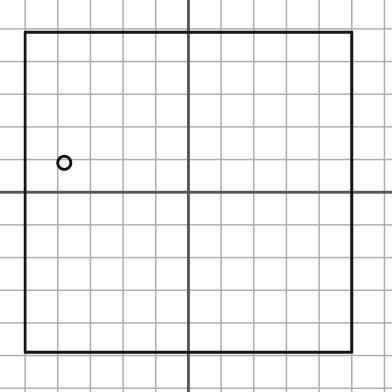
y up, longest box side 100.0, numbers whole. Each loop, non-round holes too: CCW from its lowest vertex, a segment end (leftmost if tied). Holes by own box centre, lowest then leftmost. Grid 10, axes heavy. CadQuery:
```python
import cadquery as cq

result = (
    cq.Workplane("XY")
    .moveTo(-50.0, -49.0)
    .lineTo(50.0, -49.0)
    .lineTo(50.0, 49.0)
    .lineTo(-50.0, 49.0)
    .close()
    .moveTo(-38.0, 9.0)
    .circle(2.0)
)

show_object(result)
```